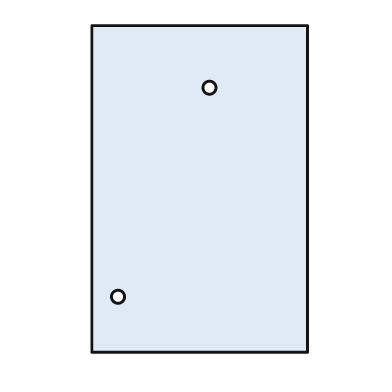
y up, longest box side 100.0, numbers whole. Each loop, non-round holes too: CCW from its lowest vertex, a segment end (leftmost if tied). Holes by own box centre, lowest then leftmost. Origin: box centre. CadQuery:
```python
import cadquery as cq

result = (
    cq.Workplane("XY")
    .moveTo(-33.0, -50.0)
    .lineTo(33.0, -50.0)
    .lineTo(33.0, 50.0)
    .lineTo(-33.0, 50.0)
    .close()
    .moveTo(-25.0, -33.0)
    .circle(2.0)
    .moveTo(3.0, 31.0)
    .circle(2.0)
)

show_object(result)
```